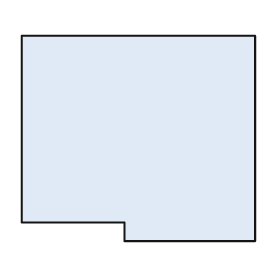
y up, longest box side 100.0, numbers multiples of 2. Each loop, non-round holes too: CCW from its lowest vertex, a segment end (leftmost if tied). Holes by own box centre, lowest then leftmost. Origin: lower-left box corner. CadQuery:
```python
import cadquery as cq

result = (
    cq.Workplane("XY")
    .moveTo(44.0, 0.0)
    .lineTo(100.0, 0.0)
    .lineTo(100.0, 88.0)
    .lineTo(0.0, 88.0)
    .lineTo(0.0, 8.0)
    .lineTo(44.0, 8.0)
    .close()
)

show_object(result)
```